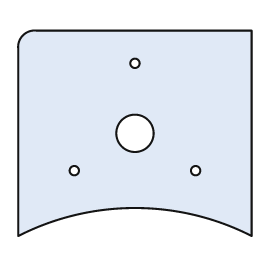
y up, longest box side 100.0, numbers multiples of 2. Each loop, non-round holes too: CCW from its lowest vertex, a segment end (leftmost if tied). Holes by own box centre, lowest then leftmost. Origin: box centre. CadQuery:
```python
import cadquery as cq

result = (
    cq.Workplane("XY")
    .moveTo(-50.0, -44.0)
    .threePointArc((0.0, -32.0), (50.0, -44.0))
    .lineTo(50.0, 44.0)
    .lineTo(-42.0, 44.0)
    .threePointArc((-48.0, 42.0), (-50.0, 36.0))
    .close()
    .moveTo(-26.0, -16.0)
    .circle(2.0)
    .moveTo(26.0, -16.0)
    .circle(2.0)
    .moveTo(0.0, 0.0)
    .circle(8.0)
    .moveTo(0.0, 30.0)
    .circle(2.0)
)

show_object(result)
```